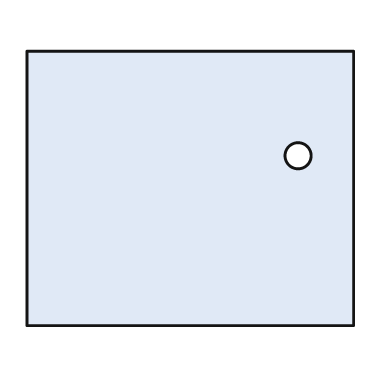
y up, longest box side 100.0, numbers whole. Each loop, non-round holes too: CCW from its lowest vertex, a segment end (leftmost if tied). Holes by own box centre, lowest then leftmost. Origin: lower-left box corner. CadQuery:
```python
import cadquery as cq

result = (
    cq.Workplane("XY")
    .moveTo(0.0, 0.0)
    .lineTo(100.0, 0.0)
    .lineTo(100.0, 84.0)
    .lineTo(0.0, 84.0)
    .close()
    .moveTo(83.0, 52.0)
    .circle(4.0)
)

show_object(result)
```